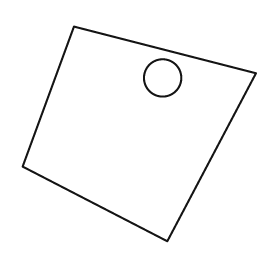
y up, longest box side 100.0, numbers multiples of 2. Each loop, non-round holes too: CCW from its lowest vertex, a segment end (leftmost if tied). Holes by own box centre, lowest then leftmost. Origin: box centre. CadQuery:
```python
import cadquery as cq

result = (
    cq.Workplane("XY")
    .moveTo(12.0, -46.0)
    .lineTo(50.0, 26.0)
    .lineTo(-28.0, 46.0)
    .lineTo(-50.0, -14.0)
    .close()
    .moveTo(10.0, 24.0)
    .circle(8.0)
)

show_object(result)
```